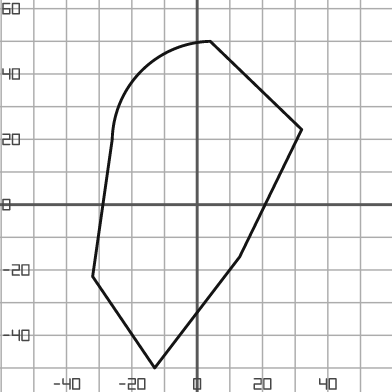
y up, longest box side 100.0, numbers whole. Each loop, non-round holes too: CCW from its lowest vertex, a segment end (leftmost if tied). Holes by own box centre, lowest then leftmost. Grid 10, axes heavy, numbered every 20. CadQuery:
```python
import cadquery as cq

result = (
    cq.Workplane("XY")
    .moveTo(-13.0, -50.0)
    .lineTo(13.0, -16.0)
    .lineTo(32.0, 23.0)
    .lineTo(4.0, 50.0)
    .threePointArc((-17.0, 41.0), (-26.0, 20.0))
    .lineTo(-32.0, -22.0)
    .close()
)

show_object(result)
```